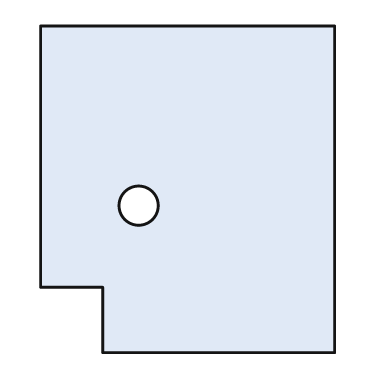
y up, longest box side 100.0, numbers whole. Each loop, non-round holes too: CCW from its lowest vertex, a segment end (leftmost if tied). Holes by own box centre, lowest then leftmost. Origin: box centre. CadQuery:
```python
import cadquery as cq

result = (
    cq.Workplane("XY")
    .moveTo(-26.0, -50.0)
    .lineTo(45.0, -50.0)
    .lineTo(45.0, 50.0)
    .lineTo(-45.0, 50.0)
    .lineTo(-45.0, -30.0)
    .lineTo(-26.0, -30.0)
    .close()
    .moveTo(-15.0, -5.0)
    .circle(6.0)
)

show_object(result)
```